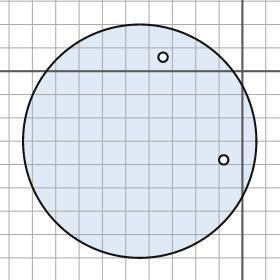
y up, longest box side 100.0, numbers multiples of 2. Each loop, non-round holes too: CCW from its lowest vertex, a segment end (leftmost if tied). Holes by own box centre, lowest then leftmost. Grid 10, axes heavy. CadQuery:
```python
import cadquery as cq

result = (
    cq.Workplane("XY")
    .moveTo(-44.0, -30.0)
    .circle(50.0)
    .moveTo(-8.0, -38.0)
    .circle(2.0)
    .moveTo(-34.0, 6.0)
    .circle(2.0)
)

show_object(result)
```